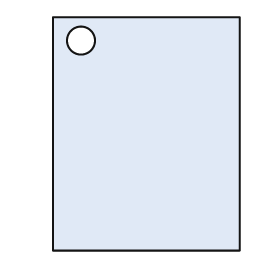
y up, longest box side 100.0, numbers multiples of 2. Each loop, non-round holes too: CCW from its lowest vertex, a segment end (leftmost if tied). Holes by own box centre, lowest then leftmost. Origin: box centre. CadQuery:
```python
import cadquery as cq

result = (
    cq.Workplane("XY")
    .moveTo(-40.0, -50.0)
    .lineTo(40.0, -50.0)
    .lineTo(40.0, 50.0)
    .lineTo(-40.0, 50.0)
    .close()
    .moveTo(-28.0, 40.0)
    .circle(6.0)
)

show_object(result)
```